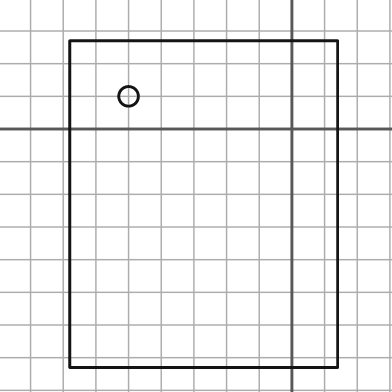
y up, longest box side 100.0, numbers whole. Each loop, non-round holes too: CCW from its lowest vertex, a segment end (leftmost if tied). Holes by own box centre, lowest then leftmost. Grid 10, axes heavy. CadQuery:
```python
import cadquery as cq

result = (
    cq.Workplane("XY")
    .moveTo(-68.0, -73.0)
    .lineTo(14.0, -73.0)
    .lineTo(14.0, 27.0)
    .lineTo(-68.0, 27.0)
    .close()
    .moveTo(-50.0, 10.0)
    .circle(3.0)
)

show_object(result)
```